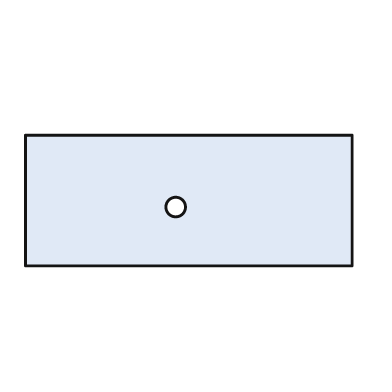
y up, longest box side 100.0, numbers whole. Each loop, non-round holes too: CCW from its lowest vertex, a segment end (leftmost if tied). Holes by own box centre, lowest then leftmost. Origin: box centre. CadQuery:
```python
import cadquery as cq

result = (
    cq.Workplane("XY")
    .moveTo(-50.0, -20.0)
    .lineTo(50.0, -20.0)
    .lineTo(50.0, 20.0)
    .lineTo(-50.0, 20.0)
    .close()
    .moveTo(-4.0, -2.0)
    .circle(3.0)
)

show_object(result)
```